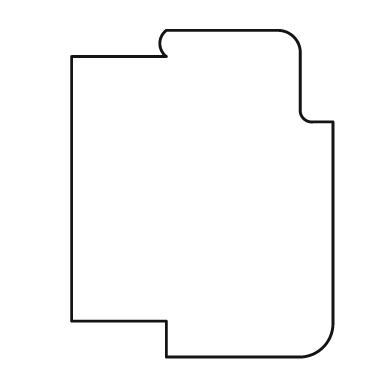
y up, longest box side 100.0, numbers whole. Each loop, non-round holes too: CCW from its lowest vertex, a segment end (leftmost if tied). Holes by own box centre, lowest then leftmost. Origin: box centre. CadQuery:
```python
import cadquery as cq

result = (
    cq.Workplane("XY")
    .moveTo(-11.0, -50.0)
    .lineTo(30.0, -50.0)
    .threePointArc((37.0, -47.0), (40.0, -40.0))
    .lineTo(40.0, 22.0)
    .lineTo(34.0, 22.0)
    .threePointArc((31.0, 23.0), (30.0, 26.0))
    .lineTo(30.0, 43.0)
    .threePointArc((28.0, 48.0), (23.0, 50.0))
    .lineTo(-11.0, 50.0)
    .threePointArc((-13.0, 46.0), (-11.0, 42.0))
    .lineTo(-40.0, 42.0)
    .lineTo(-40.0, -39.0)
    .lineTo(-11.0, -39.0)
    .close()
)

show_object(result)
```